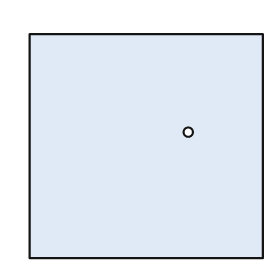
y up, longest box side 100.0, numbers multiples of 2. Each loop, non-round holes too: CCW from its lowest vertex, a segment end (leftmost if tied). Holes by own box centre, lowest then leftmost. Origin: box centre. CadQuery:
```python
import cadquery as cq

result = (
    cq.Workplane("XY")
    .moveTo(-50.0, -48.0)
    .lineTo(50.0, -48.0)
    .lineTo(50.0, 48.0)
    .lineTo(-50.0, 48.0)
    .close()
    .moveTo(18.0, 6.0)
    .circle(2.0)
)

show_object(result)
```